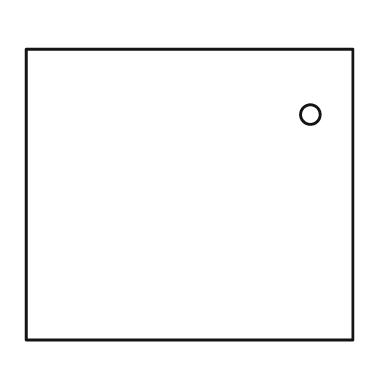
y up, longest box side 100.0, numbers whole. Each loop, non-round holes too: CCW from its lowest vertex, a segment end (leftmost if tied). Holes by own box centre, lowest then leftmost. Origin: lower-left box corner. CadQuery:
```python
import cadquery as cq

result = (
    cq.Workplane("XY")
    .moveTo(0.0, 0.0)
    .lineTo(100.0, 0.0)
    .lineTo(100.0, 89.0)
    .lineTo(0.0, 89.0)
    .close()
    .moveTo(87.0, 69.0)
    .circle(3.0)
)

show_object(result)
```